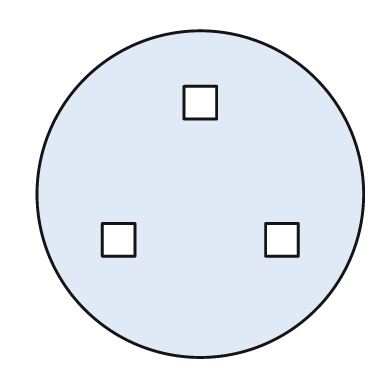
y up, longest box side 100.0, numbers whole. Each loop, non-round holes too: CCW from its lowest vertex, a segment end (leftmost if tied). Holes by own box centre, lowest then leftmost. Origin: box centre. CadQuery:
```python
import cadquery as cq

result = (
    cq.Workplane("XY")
    .moveTo(0.0, 0.0)
    .circle(50.0)
    .moveTo(-30.0, -19.0)
    .lineTo(-20.0, -19.0)
    .lineTo(-20.0, -9.0)
    .lineTo(-30.0, -9.0)
    .close()
    .moveTo(20.0, -19.0)
    .lineTo(30.0, -19.0)
    .lineTo(30.0, -9.0)
    .lineTo(20.0, -9.0)
    .close()
    .moveTo(-5.0, 23.0)
    .lineTo(5.0, 23.0)
    .lineTo(5.0, 33.0)
    .lineTo(-5.0, 33.0)
    .close()
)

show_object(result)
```